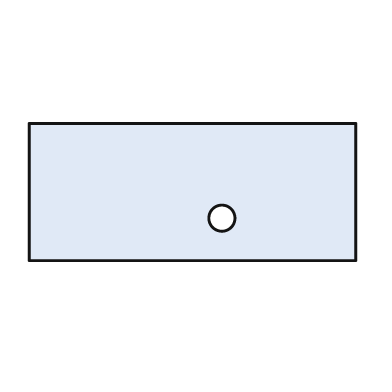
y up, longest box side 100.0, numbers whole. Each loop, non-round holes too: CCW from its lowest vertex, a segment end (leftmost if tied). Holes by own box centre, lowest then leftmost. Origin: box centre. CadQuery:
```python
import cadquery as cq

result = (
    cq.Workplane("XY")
    .moveTo(-50.0, -21.0)
    .lineTo(50.0, -21.0)
    .lineTo(50.0, 21.0)
    .lineTo(-50.0, 21.0)
    .close()
    .moveTo(9.0, -8.0)
    .circle(4.0)
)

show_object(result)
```